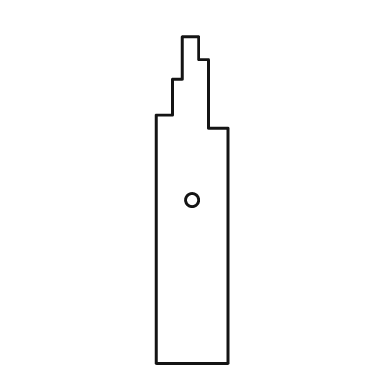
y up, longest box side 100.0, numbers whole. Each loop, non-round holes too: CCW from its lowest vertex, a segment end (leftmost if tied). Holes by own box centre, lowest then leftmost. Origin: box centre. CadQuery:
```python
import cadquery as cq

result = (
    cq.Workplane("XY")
    .moveTo(-11.0, -50.0)
    .lineTo(11.0, -50.0)
    .lineTo(11.0, 22.0)
    .lineTo(5.0, 22.0)
    .lineTo(5.0, 43.0)
    .lineTo(2.0, 43.0)
    .lineTo(2.0, 50.0)
    .lineTo(-3.0, 50.0)
    .lineTo(-3.0, 37.0)
    .lineTo(-6.0, 37.0)
    .lineTo(-6.0, 26.0)
    .lineTo(-11.0, 26.0)
    .close()
    .moveTo(0.0, 0.0)
    .circle(2.0)
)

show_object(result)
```